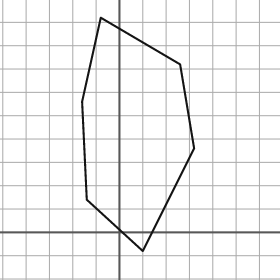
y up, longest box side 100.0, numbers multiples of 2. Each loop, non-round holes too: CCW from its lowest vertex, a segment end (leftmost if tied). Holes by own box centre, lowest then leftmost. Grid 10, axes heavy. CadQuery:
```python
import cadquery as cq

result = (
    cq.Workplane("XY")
    .moveTo(10.0, -8.0)
    .lineTo(32.0, 36.0)
    .lineTo(26.0, 72.0)
    .lineTo(-8.0, 92.0)
    .lineTo(-16.0, 56.0)
    .lineTo(-14.0, 14.0)
    .close()
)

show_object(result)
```